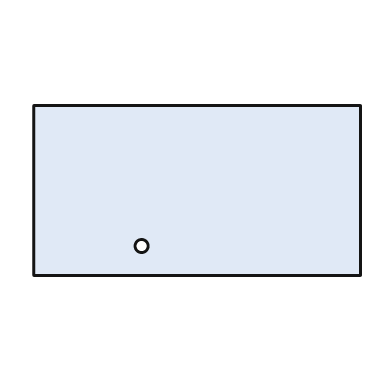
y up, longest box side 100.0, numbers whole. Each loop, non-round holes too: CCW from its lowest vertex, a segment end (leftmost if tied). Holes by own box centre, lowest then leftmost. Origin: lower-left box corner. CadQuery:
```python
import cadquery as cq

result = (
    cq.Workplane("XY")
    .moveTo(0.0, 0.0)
    .lineTo(100.0, 0.0)
    .lineTo(100.0, 52.0)
    .lineTo(0.0, 52.0)
    .close()
    .moveTo(33.0, 9.0)
    .circle(2.0)
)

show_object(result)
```